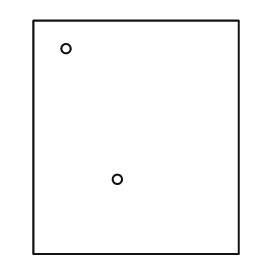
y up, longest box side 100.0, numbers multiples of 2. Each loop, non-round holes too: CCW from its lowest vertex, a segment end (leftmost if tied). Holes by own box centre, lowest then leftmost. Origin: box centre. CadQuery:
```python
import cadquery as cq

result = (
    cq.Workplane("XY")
    .moveTo(-44.0, -50.0)
    .lineTo(44.0, -50.0)
    .lineTo(44.0, 50.0)
    .lineTo(-44.0, 50.0)
    .close()
    .moveTo(-8.0, -18.0)
    .circle(2.0)
    .moveTo(-30.0, 38.0)
    .circle(2.0)
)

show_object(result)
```